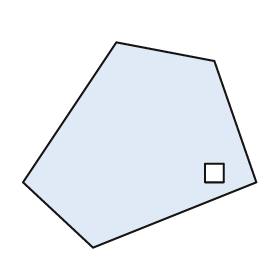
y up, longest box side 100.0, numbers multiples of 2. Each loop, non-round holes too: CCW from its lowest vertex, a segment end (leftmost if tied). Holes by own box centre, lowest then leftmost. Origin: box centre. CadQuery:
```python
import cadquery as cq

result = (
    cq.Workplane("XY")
    .moveTo(-20.0, -44.0)
    .lineTo(50.0, -16.0)
    .lineTo(32.0, 36.0)
    .lineTo(-10.0, 44.0)
    .lineTo(-50.0, -16.0)
    .close()
    .moveTo(28.0, -16.0)
    .lineTo(36.0, -16.0)
    .lineTo(36.0, -8.0)
    .lineTo(28.0, -8.0)
    .close()
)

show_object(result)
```